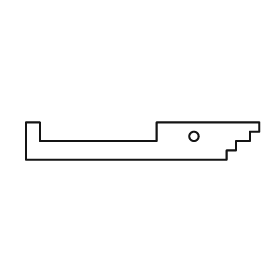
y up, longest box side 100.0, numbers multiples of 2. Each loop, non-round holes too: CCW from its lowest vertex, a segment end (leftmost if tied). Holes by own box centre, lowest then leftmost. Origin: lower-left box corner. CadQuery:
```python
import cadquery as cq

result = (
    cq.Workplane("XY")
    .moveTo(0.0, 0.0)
    .lineTo(86.0, 0.0)
    .lineTo(86.0, 4.0)
    .lineTo(90.0, 4.0)
    .lineTo(90.0, 8.0)
    .lineTo(96.0, 8.0)
    .lineTo(96.0, 12.0)
    .lineTo(100.0, 12.0)
    .lineTo(100.0, 16.0)
    .lineTo(56.0, 16.0)
    .lineTo(56.0, 8.0)
    .lineTo(6.0, 8.0)
    .lineTo(6.0, 16.0)
    .lineTo(0.0, 16.0)
    .close()
    .moveTo(72.0, 10.0)
    .circle(2.0)
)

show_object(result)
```